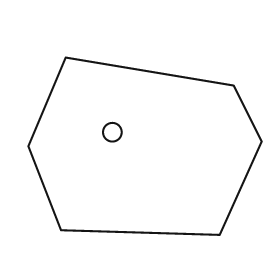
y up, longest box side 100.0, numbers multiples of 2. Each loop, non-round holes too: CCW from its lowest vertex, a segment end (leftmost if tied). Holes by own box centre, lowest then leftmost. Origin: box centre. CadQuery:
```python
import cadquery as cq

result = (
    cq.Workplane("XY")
    .moveTo(32.0, -38.0)
    .lineTo(50.0, 2.0)
    .lineTo(38.0, 26.0)
    .lineTo(-34.0, 38.0)
    .lineTo(-50.0, 0.0)
    .lineTo(-36.0, -36.0)
    .close()
    .moveTo(-14.0, 6.0)
    .circle(4.0)
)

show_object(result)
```